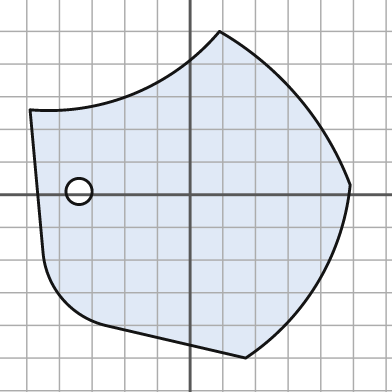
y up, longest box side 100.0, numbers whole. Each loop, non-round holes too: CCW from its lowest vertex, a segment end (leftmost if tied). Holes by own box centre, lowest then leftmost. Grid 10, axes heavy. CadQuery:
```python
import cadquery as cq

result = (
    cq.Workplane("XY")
    .moveTo(17.0, -50.0)
    .threePointArc((39.0, -27.0), (49.0, 3.0))
    .threePointArc((33.0, 30.0), (9.0, 50.0))
    .threePointArc((-17.0, 31.0), (-49.0, 26.0))
    .lineTo(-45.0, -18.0)
    .threePointArc((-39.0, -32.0), (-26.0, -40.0))
    .close()
    .moveTo(-34.0, 1.0)
    .circle(4.0)
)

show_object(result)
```